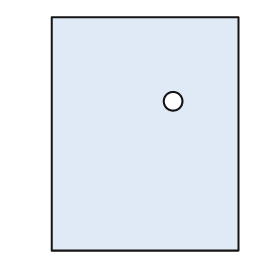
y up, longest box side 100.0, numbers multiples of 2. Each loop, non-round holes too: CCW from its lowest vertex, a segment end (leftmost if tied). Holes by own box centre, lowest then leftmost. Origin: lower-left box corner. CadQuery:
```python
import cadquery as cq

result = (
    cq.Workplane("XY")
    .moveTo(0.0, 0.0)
    .lineTo(80.0, 0.0)
    .lineTo(80.0, 100.0)
    .lineTo(0.0, 100.0)
    .close()
    .moveTo(52.0, 64.0)
    .circle(4.0)
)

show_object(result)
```